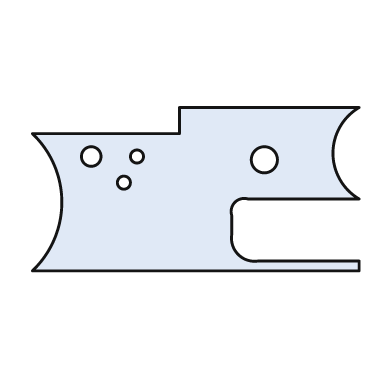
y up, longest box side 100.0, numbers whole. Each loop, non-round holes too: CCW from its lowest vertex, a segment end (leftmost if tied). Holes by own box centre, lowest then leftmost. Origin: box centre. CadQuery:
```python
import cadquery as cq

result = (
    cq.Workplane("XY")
    .moveTo(-50.0, -25.0)
    .lineTo(50.0, -25.0)
    .lineTo(50.0, -22.0)
    .lineTo(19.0, -22.0)
    .threePointArc((13.0, -20.0), (11.0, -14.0))
    .lineTo(11.0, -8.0)
    .threePointArc((12.0, -4.0), (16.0, -3.0))
    .lineTo(50.0, -3.0)
    .threePointArc((42.0, 11.0), (50.0, 25.0))
    .lineTo(-5.0, 25.0)
    .lineTo(-5.0, 17.0)
    .lineTo(-50.0, 17.0)
    .threePointArc((-41.0, -4.0), (-50.0, -25.0))
    .close()
    .moveTo(-22.0, 2.0)
    .circle(2.0)
    .moveTo(21.0, 9.0)
    .circle(4.0)
    .moveTo(-32.0, 10.0)
    .circle(3.0)
    .moveTo(-18.0, 10.0)
    .circle(2.0)
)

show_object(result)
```